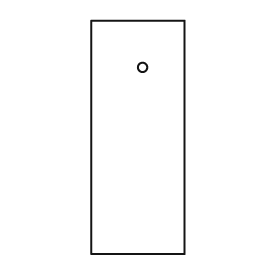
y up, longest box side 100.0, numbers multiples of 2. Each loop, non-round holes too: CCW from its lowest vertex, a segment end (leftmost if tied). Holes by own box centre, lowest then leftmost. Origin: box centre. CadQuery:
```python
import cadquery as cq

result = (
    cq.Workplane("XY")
    .moveTo(-20.0, -50.0)
    .lineTo(20.0, -50.0)
    .lineTo(20.0, 50.0)
    .lineTo(-20.0, 50.0)
    .close()
    .moveTo(2.0, 30.0)
    .circle(2.0)
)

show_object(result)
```